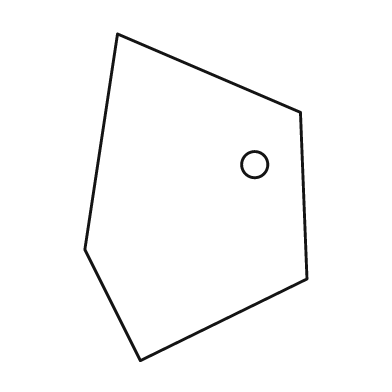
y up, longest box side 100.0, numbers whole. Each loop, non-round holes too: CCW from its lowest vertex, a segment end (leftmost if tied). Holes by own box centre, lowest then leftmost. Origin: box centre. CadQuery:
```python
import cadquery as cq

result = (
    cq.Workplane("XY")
    .moveTo(-17.0, -50.0)
    .lineTo(34.0, -25.0)
    .lineTo(32.0, 26.0)
    .lineTo(-24.0, 50.0)
    .lineTo(-34.0, -16.0)
    .close()
    .moveTo(18.0, 10.0)
    .circle(4.0)
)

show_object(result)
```